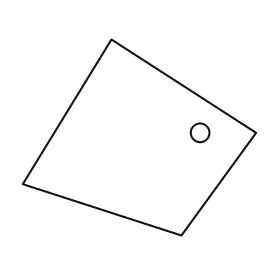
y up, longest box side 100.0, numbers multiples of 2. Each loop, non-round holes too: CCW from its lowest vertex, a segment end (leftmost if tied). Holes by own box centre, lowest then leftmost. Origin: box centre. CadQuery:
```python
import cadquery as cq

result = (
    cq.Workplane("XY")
    .moveTo(18.0, -42.0)
    .lineTo(50.0, 2.0)
    .lineTo(-12.0, 42.0)
    .lineTo(-50.0, -20.0)
    .close()
    .moveTo(26.0, 2.0)
    .circle(4.0)
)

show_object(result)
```